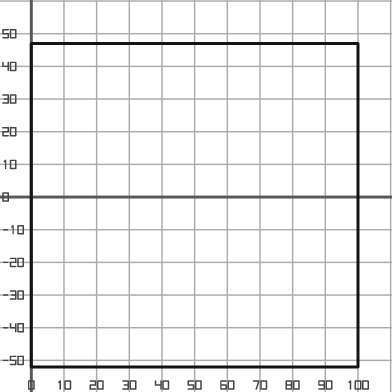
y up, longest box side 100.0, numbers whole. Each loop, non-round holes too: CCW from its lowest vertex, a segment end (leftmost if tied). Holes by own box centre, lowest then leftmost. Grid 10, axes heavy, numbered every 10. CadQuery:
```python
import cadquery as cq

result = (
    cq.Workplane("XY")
    .moveTo(0.0, -52.0)
    .lineTo(100.0, -52.0)
    .lineTo(100.0, 47.0)
    .lineTo(0.0, 47.0)
    .close()
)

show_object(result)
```